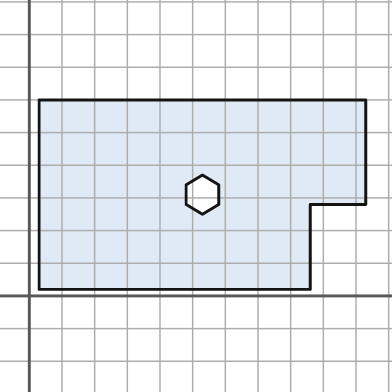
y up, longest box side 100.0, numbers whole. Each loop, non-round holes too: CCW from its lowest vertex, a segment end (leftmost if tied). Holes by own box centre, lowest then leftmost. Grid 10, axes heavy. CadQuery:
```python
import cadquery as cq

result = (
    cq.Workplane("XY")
    .moveTo(3.0, 2.0)
    .lineTo(86.0, 2.0)
    .lineTo(86.0, 28.0)
    .lineTo(103.0, 28.0)
    .lineTo(103.0, 60.0)
    .lineTo(3.0, 60.0)
    .close()
    .moveTo(53.0, 25.0)
    .lineTo(58.0, 28.0)
    .lineTo(58.0, 34.0)
    .lineTo(53.0, 37.0)
    .lineTo(48.0, 34.0)
    .lineTo(48.0, 28.0)
    .close()
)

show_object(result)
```